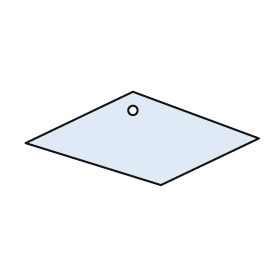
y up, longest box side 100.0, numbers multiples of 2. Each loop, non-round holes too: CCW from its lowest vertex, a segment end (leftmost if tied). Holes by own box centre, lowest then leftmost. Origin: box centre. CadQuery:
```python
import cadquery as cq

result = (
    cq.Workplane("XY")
    .moveTo(8.0, -20.0)
    .lineTo(50.0, 0.0)
    .lineTo(-4.0, 20.0)
    .lineTo(-50.0, -2.0)
    .close()
    .moveTo(-4.0, 12.0)
    .circle(2.0)
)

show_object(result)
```